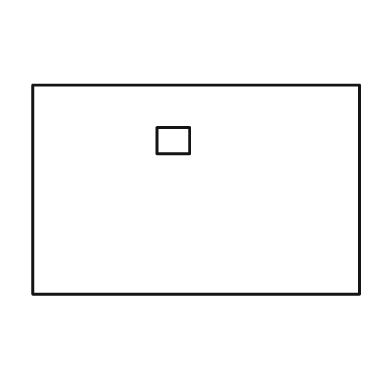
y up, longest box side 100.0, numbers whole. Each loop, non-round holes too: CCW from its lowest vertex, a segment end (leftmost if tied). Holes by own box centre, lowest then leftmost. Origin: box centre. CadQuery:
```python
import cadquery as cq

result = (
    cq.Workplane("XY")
    .moveTo(-50.0, -32.0)
    .lineTo(50.0, -32.0)
    .lineTo(50.0, 32.0)
    .lineTo(-50.0, 32.0)
    .close()
    .moveTo(-12.0, 11.0)
    .lineTo(-2.0, 11.0)
    .lineTo(-2.0, 19.0)
    .lineTo(-12.0, 19.0)
    .close()
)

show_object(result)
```